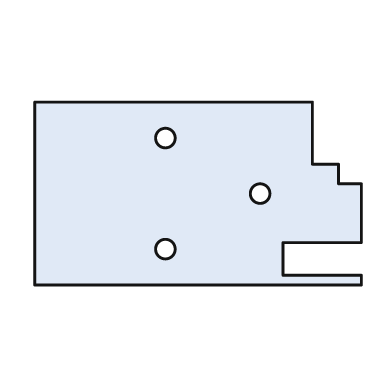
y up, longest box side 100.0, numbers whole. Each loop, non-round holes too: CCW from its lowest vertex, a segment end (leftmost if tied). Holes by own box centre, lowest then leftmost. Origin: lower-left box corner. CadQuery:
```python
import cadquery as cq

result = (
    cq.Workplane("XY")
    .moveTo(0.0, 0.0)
    .lineTo(100.0, 0.0)
    .lineTo(100.0, 3.0)
    .lineTo(76.0, 3.0)
    .lineTo(76.0, 13.0)
    .lineTo(100.0, 13.0)
    .lineTo(100.0, 31.0)
    .lineTo(93.0, 31.0)
    .lineTo(93.0, 37.0)
    .lineTo(85.0, 37.0)
    .lineTo(85.0, 56.0)
    .lineTo(0.0, 56.0)
    .close()
    .moveTo(40.0, 11.0)
    .circle(3.0)
    .moveTo(69.0, 28.0)
    .circle(3.0)
    .moveTo(40.0, 45.0)
    .circle(3.0)
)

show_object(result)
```